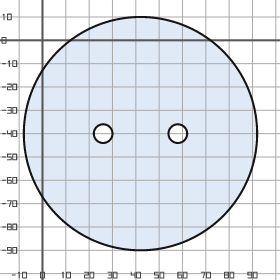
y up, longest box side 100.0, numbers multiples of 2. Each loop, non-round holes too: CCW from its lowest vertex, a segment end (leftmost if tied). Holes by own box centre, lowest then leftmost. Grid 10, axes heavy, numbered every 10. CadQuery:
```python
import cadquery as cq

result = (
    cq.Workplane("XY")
    .moveTo(42.0, -40.0)
    .circle(50.0)
    .moveTo(26.0, -40.0)
    .circle(4.0)
    .moveTo(58.0, -40.0)
    .circle(4.0)
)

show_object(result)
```